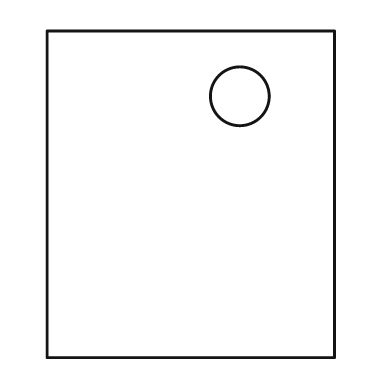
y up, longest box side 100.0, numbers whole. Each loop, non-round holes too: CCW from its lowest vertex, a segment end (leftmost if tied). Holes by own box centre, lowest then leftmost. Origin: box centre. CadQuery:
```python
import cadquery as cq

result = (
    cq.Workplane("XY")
    .moveTo(-44.0, -50.0)
    .lineTo(44.0, -50.0)
    .lineTo(44.0, 50.0)
    .lineTo(-44.0, 50.0)
    .close()
    .moveTo(15.0, 30.0)
    .circle(9.0)
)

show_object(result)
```